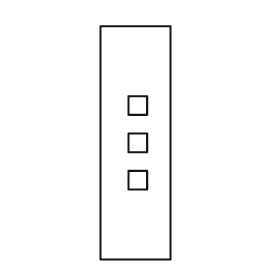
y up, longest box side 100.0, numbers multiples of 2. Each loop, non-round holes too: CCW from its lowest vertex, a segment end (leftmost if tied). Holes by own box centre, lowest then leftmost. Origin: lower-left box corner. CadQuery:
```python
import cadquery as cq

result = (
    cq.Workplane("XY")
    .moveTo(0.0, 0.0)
    .lineTo(30.0, 0.0)
    .lineTo(30.0, 100.0)
    .lineTo(0.0, 100.0)
    .close()
    .moveTo(12.0, 30.0)
    .lineTo(20.0, 30.0)
    .lineTo(20.0, 38.0)
    .lineTo(12.0, 38.0)
    .close()
    .moveTo(12.0, 46.0)
    .lineTo(20.0, 46.0)
    .lineTo(20.0, 54.0)
    .lineTo(12.0, 54.0)
    .close()
    .moveTo(12.0, 62.0)
    .lineTo(20.0, 62.0)
    .lineTo(20.0, 70.0)
    .lineTo(12.0, 70.0)
    .close()
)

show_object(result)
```